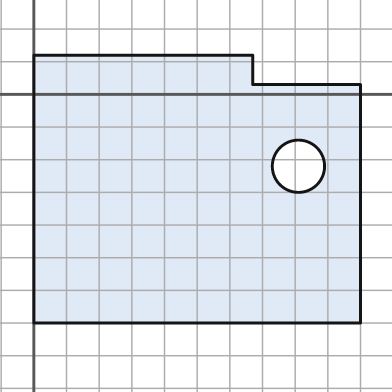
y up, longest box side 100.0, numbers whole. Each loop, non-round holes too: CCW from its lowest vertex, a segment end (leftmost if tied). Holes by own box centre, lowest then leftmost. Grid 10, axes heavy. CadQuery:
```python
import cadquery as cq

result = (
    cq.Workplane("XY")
    .moveTo(0.0, -70.0)
    .lineTo(100.0, -70.0)
    .lineTo(100.0, 3.0)
    .lineTo(67.0, 3.0)
    .lineTo(67.0, 12.0)
    .lineTo(0.0, 12.0)
    .close()
    .moveTo(81.0, -22.0)
    .circle(8.0)
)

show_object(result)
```